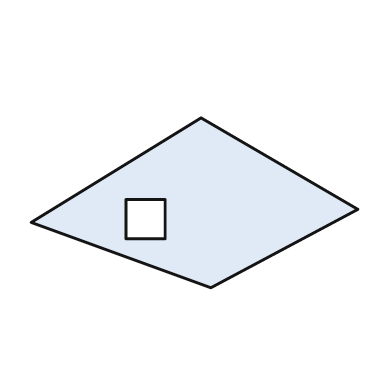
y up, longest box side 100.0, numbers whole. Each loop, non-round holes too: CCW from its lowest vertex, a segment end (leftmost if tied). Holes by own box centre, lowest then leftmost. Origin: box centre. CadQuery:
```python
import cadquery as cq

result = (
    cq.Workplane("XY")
    .moveTo(5.0, -26.0)
    .lineTo(50.0, -2.0)
    .lineTo(2.0, 26.0)
    .lineTo(-50.0, -6.0)
    .close()
    .moveTo(-21.0, -11.0)
    .lineTo(-9.0, -11.0)
    .lineTo(-9.0, 1.0)
    .lineTo(-21.0, 1.0)
    .close()
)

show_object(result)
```